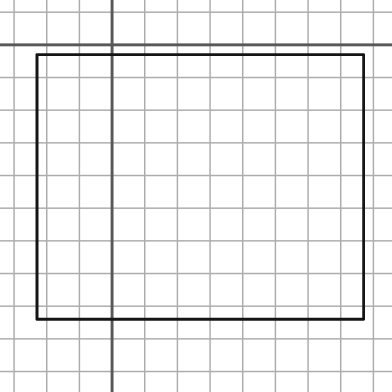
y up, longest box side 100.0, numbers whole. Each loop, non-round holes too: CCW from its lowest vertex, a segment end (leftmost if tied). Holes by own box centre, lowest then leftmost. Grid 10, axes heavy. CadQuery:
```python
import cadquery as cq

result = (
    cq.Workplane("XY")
    .moveTo(-23.0, -84.0)
    .lineTo(77.0, -84.0)
    .lineTo(77.0, -3.0)
    .lineTo(-23.0, -3.0)
    .close()
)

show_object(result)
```